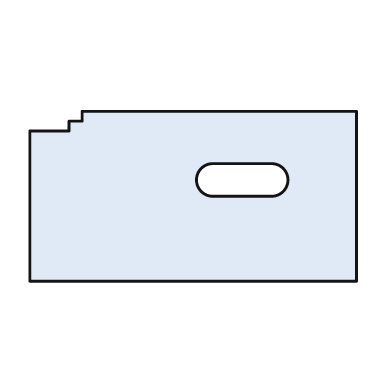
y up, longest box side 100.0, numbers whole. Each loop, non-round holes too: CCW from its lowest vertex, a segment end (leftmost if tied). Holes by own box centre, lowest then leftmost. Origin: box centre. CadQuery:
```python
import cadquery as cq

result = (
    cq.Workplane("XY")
    .moveTo(-50.0, -26.0)
    .lineTo(50.0, -26.0)
    .lineTo(50.0, 26.0)
    .lineTo(-34.0, 26.0)
    .lineTo(-34.0, 23.0)
    .lineTo(-38.0, 23.0)
    .lineTo(-38.0, 20.0)
    .lineTo(-50.0, 20.0)
    .close()
    .moveTo(6.0, 0.0)
    .lineTo(24.0, 0.0)
    .threePointArc((29.0, 5.0), (24.0, 10.0))
    .lineTo(6.0, 10.0)
    .threePointArc((1.0, 5.0), (6.0, 0.0))
    .close()
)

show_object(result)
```